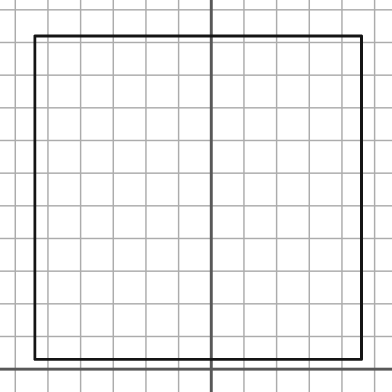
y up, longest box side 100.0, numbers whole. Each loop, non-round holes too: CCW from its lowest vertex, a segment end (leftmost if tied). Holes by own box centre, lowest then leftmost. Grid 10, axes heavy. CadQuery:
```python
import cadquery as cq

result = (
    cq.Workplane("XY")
    .moveTo(-54.0, 3.0)
    .lineTo(46.0, 3.0)
    .lineTo(46.0, 102.0)
    .lineTo(-54.0, 102.0)
    .close()
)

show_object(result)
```